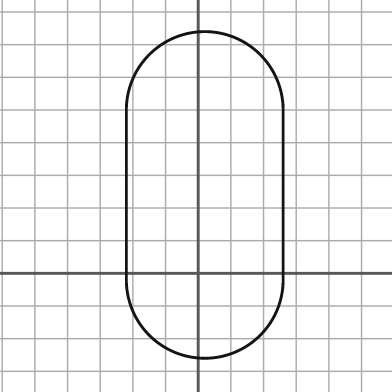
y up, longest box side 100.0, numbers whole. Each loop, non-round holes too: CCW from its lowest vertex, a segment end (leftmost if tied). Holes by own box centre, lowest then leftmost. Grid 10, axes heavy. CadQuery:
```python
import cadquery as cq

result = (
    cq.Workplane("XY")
    .moveTo(-22.0, -2.0)
    .threePointArc((2.0, -26.0), (26.0, -2.0))
    .lineTo(26.0, 50.0)
    .threePointArc((2.0, 74.0), (-22.0, 50.0))
    .close()
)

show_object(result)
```